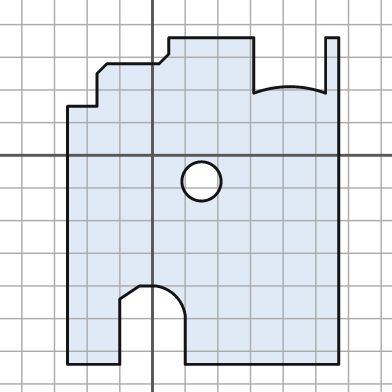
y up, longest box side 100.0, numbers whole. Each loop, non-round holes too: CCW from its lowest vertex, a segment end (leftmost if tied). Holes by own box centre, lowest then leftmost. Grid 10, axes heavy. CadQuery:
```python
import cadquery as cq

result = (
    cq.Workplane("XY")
    .moveTo(-26.0, -64.0)
    .lineTo(-10.0, -64.0)
    .lineTo(-10.0, -44.0)
    .lineTo(-4.0, -40.0)
    .lineTo(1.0, -40.0)
    .threePointArc((7.0, -43.0), (10.0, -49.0))
    .lineTo(10.0, -64.0)
    .lineTo(57.0, -64.0)
    .lineTo(57.0, 36.0)
    .lineTo(53.0, 36.0)
    .lineTo(53.0, 19.0)
    .threePointArc((42.0, 21.0), (31.0, 19.0))
    .lineTo(31.0, 36.0)
    .lineTo(5.0, 36.0)
    .lineTo(5.0, 31.0)
    .lineTo(2.0, 28.0)
    .lineTo(-14.0, 28.0)
    .lineTo(-17.0, 25.0)
    .lineTo(-17.0, 15.0)
    .lineTo(-26.0, 15.0)
    .close()
    .moveTo(15.0, -8.0)
    .circle(6.0)
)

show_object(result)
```